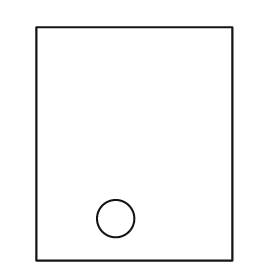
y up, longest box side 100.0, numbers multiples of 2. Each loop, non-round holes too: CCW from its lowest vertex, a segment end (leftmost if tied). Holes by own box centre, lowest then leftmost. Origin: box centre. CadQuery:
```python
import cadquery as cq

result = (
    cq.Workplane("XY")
    .moveTo(-42.0, -50.0)
    .lineTo(42.0, -50.0)
    .lineTo(42.0, 50.0)
    .lineTo(-42.0, 50.0)
    .close()
    .moveTo(-8.0, -32.0)
    .circle(8.0)
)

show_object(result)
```